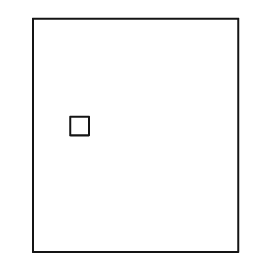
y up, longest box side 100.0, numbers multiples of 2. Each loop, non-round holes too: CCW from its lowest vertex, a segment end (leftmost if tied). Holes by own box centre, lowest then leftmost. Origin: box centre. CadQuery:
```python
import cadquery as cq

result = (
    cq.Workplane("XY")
    .moveTo(-44.0, -50.0)
    .lineTo(44.0, -50.0)
    .lineTo(44.0, 50.0)
    .lineTo(-44.0, 50.0)
    .close()
    .moveTo(-28.0, 0.0)
    .lineTo(-20.0, 0.0)
    .lineTo(-20.0, 8.0)
    .lineTo(-28.0, 8.0)
    .close()
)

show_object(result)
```